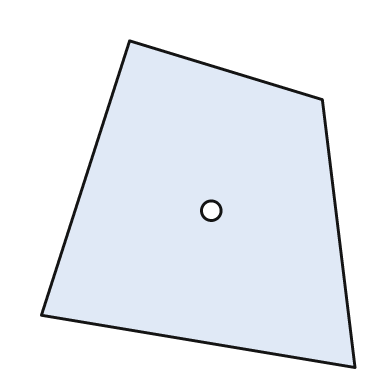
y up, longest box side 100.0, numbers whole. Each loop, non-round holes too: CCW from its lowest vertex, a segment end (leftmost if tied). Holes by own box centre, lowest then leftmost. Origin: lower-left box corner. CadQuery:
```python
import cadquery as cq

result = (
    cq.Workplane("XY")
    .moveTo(96.0, 0.0)
    .lineTo(86.0, 82.0)
    .lineTo(27.0, 100.0)
    .lineTo(0.0, 16.0)
    .close()
    .moveTo(52.0, 48.0)
    .circle(3.0)
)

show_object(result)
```